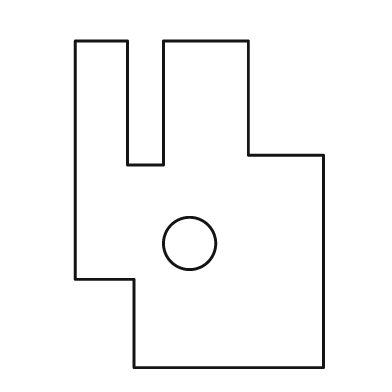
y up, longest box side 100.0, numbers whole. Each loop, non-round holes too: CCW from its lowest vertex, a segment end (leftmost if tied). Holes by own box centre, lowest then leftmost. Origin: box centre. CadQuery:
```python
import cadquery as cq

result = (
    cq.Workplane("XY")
    .moveTo(-20.0, -50.0)
    .lineTo(38.0, -50.0)
    .lineTo(38.0, 15.0)
    .lineTo(15.0, 15.0)
    .lineTo(15.0, 50.0)
    .lineTo(-11.0, 50.0)
    .lineTo(-11.0, 12.0)
    .lineTo(-22.0, 12.0)
    .lineTo(-22.0, 50.0)
    .lineTo(-38.0, 50.0)
    .lineTo(-38.0, -23.0)
    .lineTo(-20.0, -23.0)
    .close()
    .moveTo(-3.0, -12.0)
    .circle(8.0)
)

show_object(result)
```